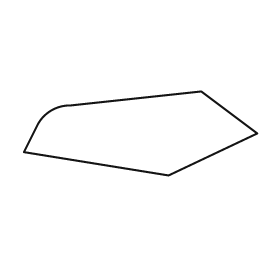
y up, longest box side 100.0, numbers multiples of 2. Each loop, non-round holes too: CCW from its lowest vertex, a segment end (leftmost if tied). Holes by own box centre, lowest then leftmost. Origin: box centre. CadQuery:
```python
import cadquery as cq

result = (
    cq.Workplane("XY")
    .moveTo(12.0, -18.0)
    .lineTo(50.0, 0.0)
    .lineTo(26.0, 18.0)
    .lineTo(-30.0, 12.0)
    .threePointArc((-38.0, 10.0), (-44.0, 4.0))
    .lineTo(-50.0, -8.0)
    .close()
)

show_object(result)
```